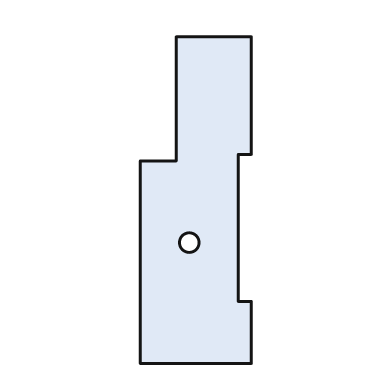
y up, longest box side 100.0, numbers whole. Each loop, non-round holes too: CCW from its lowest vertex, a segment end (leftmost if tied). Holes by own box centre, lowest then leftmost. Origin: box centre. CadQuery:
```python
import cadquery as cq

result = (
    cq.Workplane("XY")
    .moveTo(-17.0, -50.0)
    .lineTo(17.0, -50.0)
    .lineTo(17.0, -31.0)
    .lineTo(13.0, -31.0)
    .lineTo(13.0, 14.0)
    .lineTo(17.0, 14.0)
    .lineTo(17.0, 50.0)
    .lineTo(-6.0, 50.0)
    .lineTo(-6.0, 12.0)
    .lineTo(-17.0, 12.0)
    .close()
    .moveTo(-2.0, -13.0)
    .circle(3.0)
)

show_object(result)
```